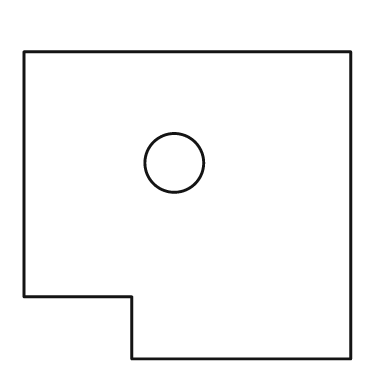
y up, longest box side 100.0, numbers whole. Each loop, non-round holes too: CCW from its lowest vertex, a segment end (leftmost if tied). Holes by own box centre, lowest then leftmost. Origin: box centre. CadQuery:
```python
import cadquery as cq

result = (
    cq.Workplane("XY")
    .moveTo(-17.0, -47.0)
    .lineTo(50.0, -47.0)
    .lineTo(50.0, 47.0)
    .lineTo(-50.0, 47.0)
    .lineTo(-50.0, -28.0)
    .lineTo(-17.0, -28.0)
    .close()
    .moveTo(-4.0, 13.0)
    .circle(9.0)
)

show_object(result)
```